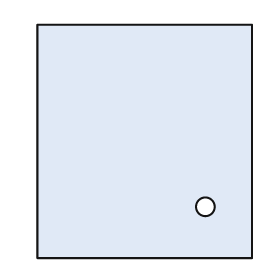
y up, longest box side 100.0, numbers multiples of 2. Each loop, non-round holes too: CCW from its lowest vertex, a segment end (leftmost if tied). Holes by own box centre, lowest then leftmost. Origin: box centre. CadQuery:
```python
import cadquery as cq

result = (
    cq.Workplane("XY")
    .moveTo(-46.0, -50.0)
    .lineTo(46.0, -50.0)
    .lineTo(46.0, 50.0)
    .lineTo(-46.0, 50.0)
    .close()
    .moveTo(26.0, -28.0)
    .circle(4.0)
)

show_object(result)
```